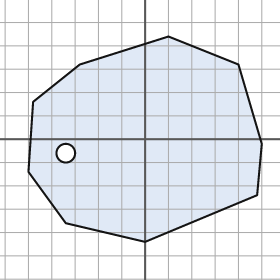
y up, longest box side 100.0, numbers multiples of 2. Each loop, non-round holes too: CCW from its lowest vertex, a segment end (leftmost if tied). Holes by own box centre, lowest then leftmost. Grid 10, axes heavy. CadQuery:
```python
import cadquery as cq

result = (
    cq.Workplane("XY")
    .moveTo(0.0, -44.0)
    .lineTo(48.0, -24.0)
    .lineTo(50.0, -2.0)
    .lineTo(40.0, 32.0)
    .lineTo(10.0, 44.0)
    .lineTo(-28.0, 32.0)
    .lineTo(-48.0, 16.0)
    .lineTo(-50.0, -14.0)
    .lineTo(-34.0, -36.0)
    .close()
    .moveTo(-34.0, -6.0)
    .circle(4.0)
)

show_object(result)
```